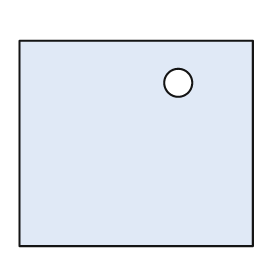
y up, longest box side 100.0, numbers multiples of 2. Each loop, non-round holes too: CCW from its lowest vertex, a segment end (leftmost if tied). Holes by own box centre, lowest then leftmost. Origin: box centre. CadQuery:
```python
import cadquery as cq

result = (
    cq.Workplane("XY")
    .moveTo(-50.0, -44.0)
    .lineTo(50.0, -44.0)
    .lineTo(50.0, 44.0)
    .lineTo(-50.0, 44.0)
    .close()
    .moveTo(18.0, 26.0)
    .circle(6.0)
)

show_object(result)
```